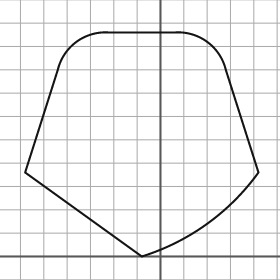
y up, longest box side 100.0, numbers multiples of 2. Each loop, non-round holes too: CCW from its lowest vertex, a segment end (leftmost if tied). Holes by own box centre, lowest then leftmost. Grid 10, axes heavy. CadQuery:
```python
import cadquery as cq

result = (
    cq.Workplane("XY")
    .moveTo(-8.0, 0.0)
    .threePointArc((20.0, 14.0), (42.0, 36.0))
    .lineTo(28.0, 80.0)
    .threePointArc((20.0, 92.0), (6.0, 96.0))
    .lineTo(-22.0, 96.0)
    .threePointArc((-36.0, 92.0), (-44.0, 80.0))
    .lineTo(-58.0, 36.0)
    .close()
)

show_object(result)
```